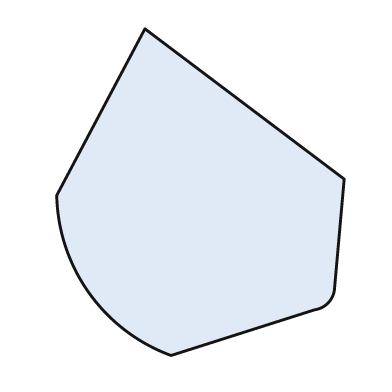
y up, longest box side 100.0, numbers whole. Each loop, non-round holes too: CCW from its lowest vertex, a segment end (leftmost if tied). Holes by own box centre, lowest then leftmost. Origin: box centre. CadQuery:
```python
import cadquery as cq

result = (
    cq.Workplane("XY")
    .moveTo(-9.0, -50.0)
    .lineTo(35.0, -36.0)
    .threePointArc((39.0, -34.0), (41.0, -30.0))
    .lineTo(44.0, 4.0)
    .lineTo(-17.0, 50.0)
    .lineTo(-44.0, -1.0)
    .threePointArc((-34.0, -31.0), (-9.0, -50.0))
    .close()
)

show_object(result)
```